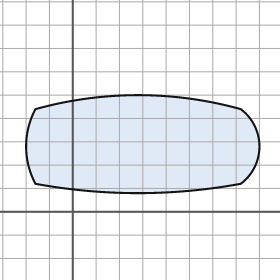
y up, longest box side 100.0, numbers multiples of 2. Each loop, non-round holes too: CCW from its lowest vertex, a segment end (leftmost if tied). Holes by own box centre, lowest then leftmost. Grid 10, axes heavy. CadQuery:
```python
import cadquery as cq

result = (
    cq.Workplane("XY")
    .moveTo(-16.0, 12.0)
    .threePointArc((28.0, 8.0), (72.0, 12.0))
    .threePointArc((80.0, 28.0), (72.0, 44.0))
    .threePointArc((28.0, 50.0), (-16.0, 44.0))
    .threePointArc((-20.0, 28.0), (-16.0, 12.0))
    .close()
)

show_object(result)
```